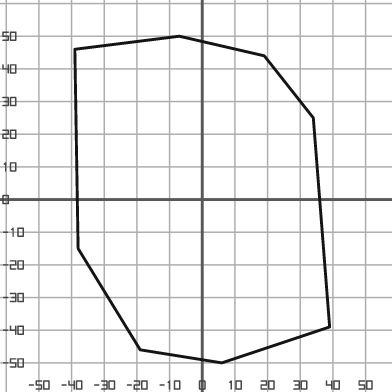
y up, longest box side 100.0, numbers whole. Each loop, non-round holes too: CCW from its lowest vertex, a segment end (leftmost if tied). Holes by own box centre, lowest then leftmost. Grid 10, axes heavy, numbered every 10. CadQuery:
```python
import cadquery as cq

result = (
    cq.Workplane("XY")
    .moveTo(6.0, -50.0)
    .lineTo(39.0, -39.0)
    .lineTo(34.0, 25.0)
    .lineTo(19.0, 44.0)
    .lineTo(-7.0, 50.0)
    .lineTo(-39.0, 46.0)
    .lineTo(-38.0, -15.0)
    .lineTo(-19.0, -46.0)
    .close()
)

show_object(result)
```